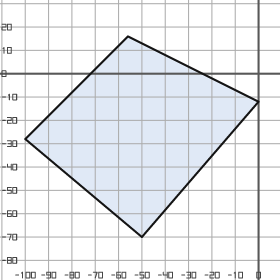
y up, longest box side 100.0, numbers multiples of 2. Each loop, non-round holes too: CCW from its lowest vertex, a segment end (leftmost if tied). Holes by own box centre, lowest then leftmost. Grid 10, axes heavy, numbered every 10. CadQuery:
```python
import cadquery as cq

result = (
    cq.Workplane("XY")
    .moveTo(-50.0, -70.0)
    .lineTo(0.0, -12.0)
    .lineTo(-56.0, 16.0)
    .lineTo(-100.0, -28.0)
    .close()
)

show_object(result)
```